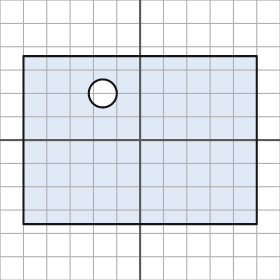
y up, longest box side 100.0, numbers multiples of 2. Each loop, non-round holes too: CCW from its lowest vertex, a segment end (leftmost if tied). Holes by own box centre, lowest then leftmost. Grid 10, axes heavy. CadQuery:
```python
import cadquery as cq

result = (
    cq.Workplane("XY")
    .moveTo(-50.0, -36.0)
    .lineTo(50.0, -36.0)
    .lineTo(50.0, 36.0)
    .lineTo(-50.0, 36.0)
    .close()
    .moveTo(-16.0, 20.0)
    .circle(6.0)
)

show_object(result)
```